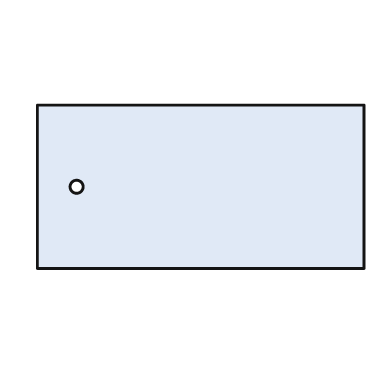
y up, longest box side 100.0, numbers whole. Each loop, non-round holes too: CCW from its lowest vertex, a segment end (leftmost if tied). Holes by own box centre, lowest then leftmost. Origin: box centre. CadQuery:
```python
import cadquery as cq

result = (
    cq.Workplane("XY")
    .moveTo(-50.0, -25.0)
    .lineTo(50.0, -25.0)
    .lineTo(50.0, 25.0)
    .lineTo(-50.0, 25.0)
    .close()
    .moveTo(-38.0, 0.0)
    .circle(2.0)
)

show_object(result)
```